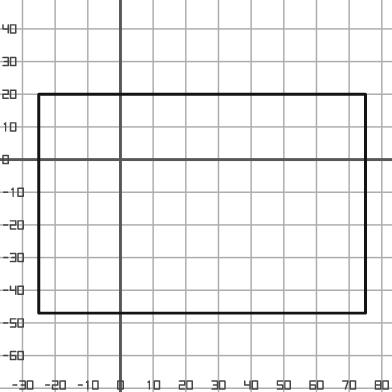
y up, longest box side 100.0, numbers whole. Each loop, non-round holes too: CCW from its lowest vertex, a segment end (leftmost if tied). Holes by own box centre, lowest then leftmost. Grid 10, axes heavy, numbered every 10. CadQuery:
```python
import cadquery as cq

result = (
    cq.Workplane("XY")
    .moveTo(-25.0, -47.0)
    .lineTo(75.0, -47.0)
    .lineTo(75.0, 20.0)
    .lineTo(-25.0, 20.0)
    .close()
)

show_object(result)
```